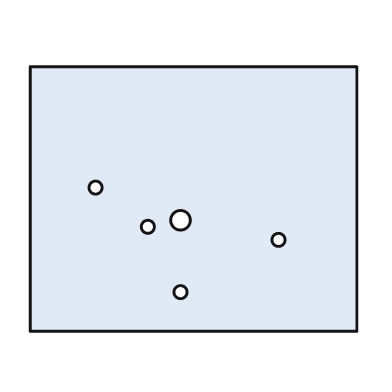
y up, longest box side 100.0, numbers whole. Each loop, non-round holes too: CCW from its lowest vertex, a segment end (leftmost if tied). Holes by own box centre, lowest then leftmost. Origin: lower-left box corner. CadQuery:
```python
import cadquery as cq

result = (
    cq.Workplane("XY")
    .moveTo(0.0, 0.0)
    .lineTo(100.0, 0.0)
    .lineTo(100.0, 81.0)
    .lineTo(0.0, 81.0)
    .close()
    .moveTo(46.0, 12.0)
    .circle(2.0)
    .moveTo(76.0, 28.0)
    .circle(2.0)
    .moveTo(36.0, 32.0)
    .circle(2.0)
    .moveTo(46.0, 34.0)
    .circle(3.0)
    .moveTo(20.0, 44.0)
    .circle(2.0)
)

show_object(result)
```